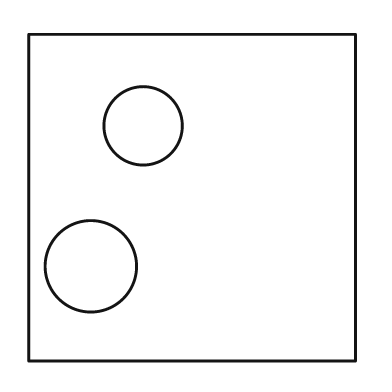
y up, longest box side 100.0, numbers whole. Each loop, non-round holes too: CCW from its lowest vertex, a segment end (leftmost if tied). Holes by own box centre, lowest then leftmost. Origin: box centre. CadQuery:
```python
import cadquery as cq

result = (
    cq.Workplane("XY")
    .moveTo(-50.0, -50.0)
    .lineTo(50.0, -50.0)
    .lineTo(50.0, 50.0)
    .lineTo(-50.0, 50.0)
    .close()
    .moveTo(-31.0, -21.0)
    .circle(14.0)
    .moveTo(-15.0, 22.0)
    .circle(12.0)
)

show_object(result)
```